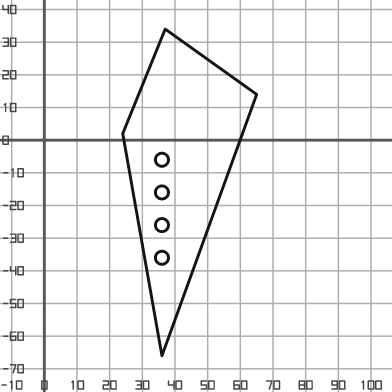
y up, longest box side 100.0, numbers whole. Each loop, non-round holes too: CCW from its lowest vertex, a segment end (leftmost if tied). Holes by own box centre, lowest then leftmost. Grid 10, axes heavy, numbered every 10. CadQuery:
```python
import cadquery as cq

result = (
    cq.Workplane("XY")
    .moveTo(36.0, -66.0)
    .lineTo(65.0, 14.0)
    .lineTo(37.0, 34.0)
    .lineTo(24.0, 2.0)
    .close()
    .moveTo(36.0, -36.0)
    .circle(2.0)
    .moveTo(36.0, -26.0)
    .circle(2.0)
    .moveTo(36.0, -16.0)
    .circle(2.0)
    .moveTo(36.0, -6.0)
    .circle(2.0)
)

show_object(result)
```